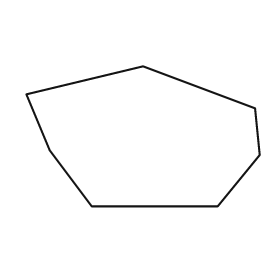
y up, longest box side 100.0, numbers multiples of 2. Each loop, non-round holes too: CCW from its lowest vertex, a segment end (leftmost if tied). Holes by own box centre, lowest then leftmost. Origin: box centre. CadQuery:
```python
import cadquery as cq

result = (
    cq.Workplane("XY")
    .moveTo(-22.0, -30.0)
    .lineTo(32.0, -30.0)
    .lineTo(50.0, -8.0)
    .lineTo(48.0, 12.0)
    .lineTo(0.0, 30.0)
    .lineTo(-50.0, 18.0)
    .lineTo(-40.0, -6.0)
    .close()
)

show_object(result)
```